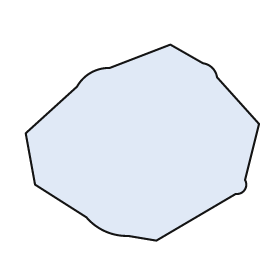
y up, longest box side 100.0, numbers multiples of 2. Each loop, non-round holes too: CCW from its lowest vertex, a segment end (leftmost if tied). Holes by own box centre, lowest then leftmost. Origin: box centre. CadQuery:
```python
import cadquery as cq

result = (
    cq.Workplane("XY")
    .moveTo(6.0, -42.0)
    .lineTo(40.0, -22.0)
    .threePointArc((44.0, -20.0), (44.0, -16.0))
    .lineTo(50.0, 8.0)
    .lineTo(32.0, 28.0)
    .threePointArc((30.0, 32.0), (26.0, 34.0))
    .lineTo(12.0, 42.0)
    .lineTo(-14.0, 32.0)
    .threePointArc((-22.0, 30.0), (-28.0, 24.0))
    .lineTo(-50.0, 4.0)
    .lineTo(-46.0, -18.0)
    .lineTo(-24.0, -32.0)
    .threePointArc((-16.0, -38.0), (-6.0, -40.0))
    .close()
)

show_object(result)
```